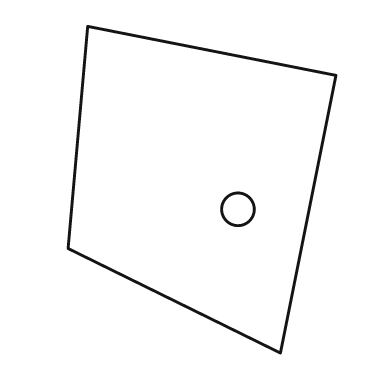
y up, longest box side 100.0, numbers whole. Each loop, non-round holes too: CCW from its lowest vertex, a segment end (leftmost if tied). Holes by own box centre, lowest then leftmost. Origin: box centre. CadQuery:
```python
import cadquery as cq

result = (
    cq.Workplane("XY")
    .moveTo(24.0, -50.0)
    .lineTo(41.0, 35.0)
    .lineTo(-35.0, 50.0)
    .lineTo(-41.0, -18.0)
    .close()
    .moveTo(11.0, -6.0)
    .circle(5.0)
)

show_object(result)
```